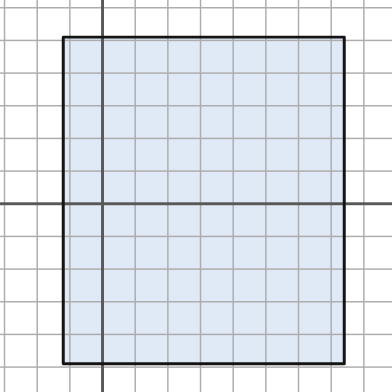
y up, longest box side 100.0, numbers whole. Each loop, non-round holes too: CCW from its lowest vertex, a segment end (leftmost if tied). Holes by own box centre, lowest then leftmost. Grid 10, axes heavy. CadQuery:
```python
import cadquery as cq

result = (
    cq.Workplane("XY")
    .moveTo(-12.0, -49.0)
    .lineTo(74.0, -49.0)
    .lineTo(74.0, 51.0)
    .lineTo(-12.0, 51.0)
    .close()
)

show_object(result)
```